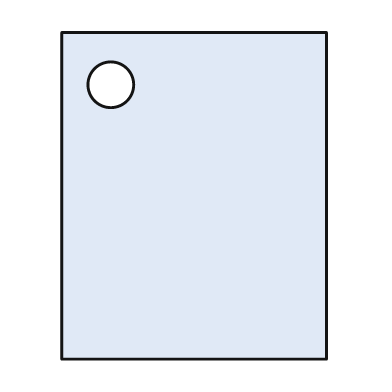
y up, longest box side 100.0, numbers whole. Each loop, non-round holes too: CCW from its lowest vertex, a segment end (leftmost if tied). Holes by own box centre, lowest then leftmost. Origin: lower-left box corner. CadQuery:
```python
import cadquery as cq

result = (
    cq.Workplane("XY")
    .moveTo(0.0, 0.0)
    .lineTo(81.0, 0.0)
    .lineTo(81.0, 100.0)
    .lineTo(0.0, 100.0)
    .close()
    .moveTo(15.0, 84.0)
    .circle(7.0)
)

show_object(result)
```